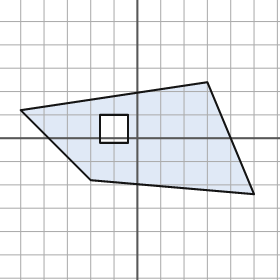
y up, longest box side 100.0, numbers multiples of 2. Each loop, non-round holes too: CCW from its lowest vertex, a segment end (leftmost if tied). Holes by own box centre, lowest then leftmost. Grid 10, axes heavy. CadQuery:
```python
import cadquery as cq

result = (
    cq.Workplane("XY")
    .moveTo(50.0, -24.0)
    .lineTo(30.0, 24.0)
    .lineTo(-50.0, 12.0)
    .lineTo(-20.0, -18.0)
    .close()
    .moveTo(-16.0, -2.0)
    .lineTo(-4.0, -2.0)
    .lineTo(-4.0, 10.0)
    .lineTo(-16.0, 10.0)
    .close()
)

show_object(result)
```